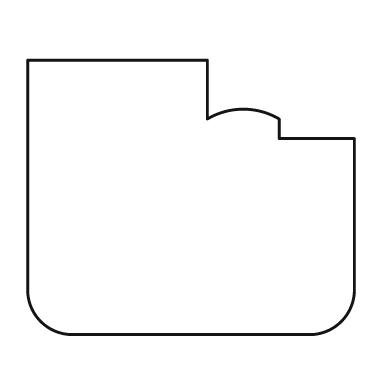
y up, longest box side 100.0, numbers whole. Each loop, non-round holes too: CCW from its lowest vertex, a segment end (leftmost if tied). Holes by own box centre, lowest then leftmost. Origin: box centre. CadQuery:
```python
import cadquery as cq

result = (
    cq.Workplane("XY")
    .moveTo(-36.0, -42.0)
    .lineTo(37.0, -42.0)
    .threePointArc((46.0, -38.0), (50.0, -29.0))
    .lineTo(50.0, 18.0)
    .lineTo(27.0, 18.0)
    .lineTo(27.0, 24.0)
    .threePointArc((16.0, 27.0), (5.0, 24.0))
    .lineTo(5.0, 42.0)
    .lineTo(-50.0, 42.0)
    .lineTo(-50.0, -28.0)
    .threePointArc((-46.0, -38.0), (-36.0, -42.0))
    .close()
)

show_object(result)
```